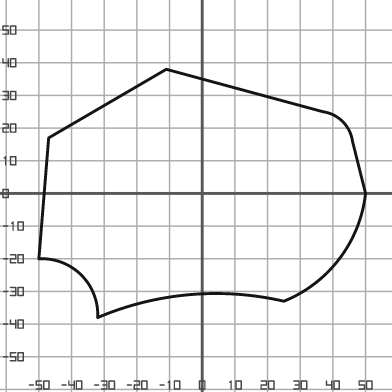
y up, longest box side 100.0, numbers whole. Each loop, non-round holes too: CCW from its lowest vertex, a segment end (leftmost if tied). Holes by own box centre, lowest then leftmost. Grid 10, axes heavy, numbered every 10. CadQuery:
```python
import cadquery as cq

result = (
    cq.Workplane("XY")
    .moveTo(-32.0, -38.0)
    .threePointArc((-4.0, -31.0), (25.0, -33.0))
    .threePointArc((42.0, -20.0), (50.0, 0.0))
    .lineTo(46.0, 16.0)
    .threePointArc((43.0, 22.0), (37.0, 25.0))
    .lineTo(-11.0, 38.0)
    .lineTo(-47.0, 17.0)
    .lineTo(-50.0, -20.0)
    .threePointArc((-37.0, -25.0), (-32.0, -38.0))
    .close()
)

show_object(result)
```